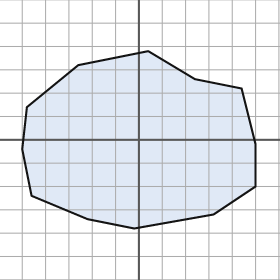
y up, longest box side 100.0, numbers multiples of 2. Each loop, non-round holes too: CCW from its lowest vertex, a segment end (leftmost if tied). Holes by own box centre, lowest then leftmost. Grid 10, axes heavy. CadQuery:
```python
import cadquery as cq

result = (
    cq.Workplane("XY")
    .moveTo(-2.0, -38.0)
    .lineTo(32.0, -32.0)
    .lineTo(50.0, -20.0)
    .lineTo(50.0, -2.0)
    .lineTo(44.0, 22.0)
    .lineTo(24.0, 26.0)
    .lineTo(4.0, 38.0)
    .lineTo(-26.0, 32.0)
    .lineTo(-48.0, 14.0)
    .lineTo(-50.0, -4.0)
    .lineTo(-46.0, -24.0)
    .lineTo(-22.0, -34.0)
    .close()
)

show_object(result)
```